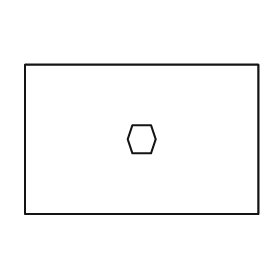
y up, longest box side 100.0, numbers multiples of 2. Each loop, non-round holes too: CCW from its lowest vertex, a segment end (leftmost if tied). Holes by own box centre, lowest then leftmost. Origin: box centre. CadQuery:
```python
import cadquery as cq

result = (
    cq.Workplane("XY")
    .moveTo(-50.0, -32.0)
    .lineTo(50.0, -32.0)
    .lineTo(50.0, 32.0)
    .lineTo(-50.0, 32.0)
    .close()
    .moveTo(-4.0, -6.0)
    .lineTo(4.0, -6.0)
    .lineTo(6.0, 0.0)
    .lineTo(4.0, 6.0)
    .lineTo(-4.0, 6.0)
    .lineTo(-6.0, 0.0)
    .close()
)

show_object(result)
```